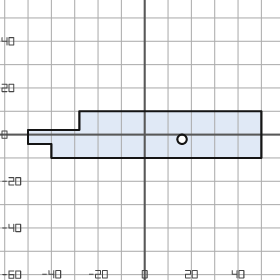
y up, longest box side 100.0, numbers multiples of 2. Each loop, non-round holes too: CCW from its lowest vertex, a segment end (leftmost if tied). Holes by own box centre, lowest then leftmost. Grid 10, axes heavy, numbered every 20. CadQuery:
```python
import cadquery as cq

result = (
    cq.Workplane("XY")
    .moveTo(-40.0, -10.0)
    .lineTo(50.0, -10.0)
    .lineTo(50.0, 10.0)
    .lineTo(-28.0, 10.0)
    .lineTo(-28.0, 2.0)
    .lineTo(-50.0, 2.0)
    .lineTo(-50.0, -4.0)
    .lineTo(-40.0, -4.0)
    .close()
    .moveTo(16.0, -2.0)
    .circle(2.0)
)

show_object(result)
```